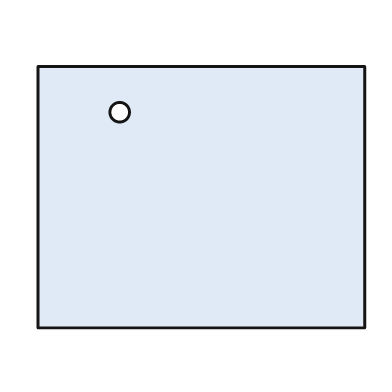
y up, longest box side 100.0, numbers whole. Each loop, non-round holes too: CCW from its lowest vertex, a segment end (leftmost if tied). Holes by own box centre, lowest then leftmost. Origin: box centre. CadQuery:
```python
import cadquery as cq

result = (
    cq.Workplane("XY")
    .moveTo(-50.0, -40.0)
    .lineTo(50.0, -40.0)
    .lineTo(50.0, 40.0)
    .lineTo(-50.0, 40.0)
    .close()
    .moveTo(-25.0, 26.0)
    .circle(3.0)
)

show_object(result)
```